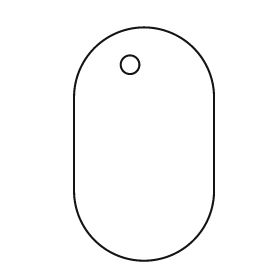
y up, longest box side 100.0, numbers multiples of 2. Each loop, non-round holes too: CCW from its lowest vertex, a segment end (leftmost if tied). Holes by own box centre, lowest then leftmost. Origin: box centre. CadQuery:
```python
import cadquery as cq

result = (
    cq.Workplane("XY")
    .moveTo(-30.0, -20.0)
    .threePointArc((0.0, -50.0), (30.0, -20.0))
    .lineTo(30.0, 20.0)
    .threePointArc((0.0, 50.0), (-30.0, 20.0))
    .close()
    .moveTo(-6.0, 34.0)
    .circle(4.0)
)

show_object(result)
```